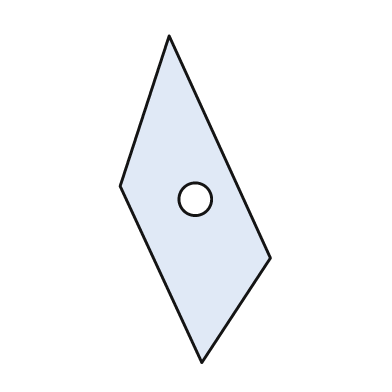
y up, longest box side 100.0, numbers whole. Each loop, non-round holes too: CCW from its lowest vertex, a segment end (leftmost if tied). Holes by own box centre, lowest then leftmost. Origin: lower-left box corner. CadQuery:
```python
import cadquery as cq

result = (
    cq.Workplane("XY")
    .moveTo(25.0, 0.0)
    .lineTo(46.0, 32.0)
    .lineTo(15.0, 100.0)
    .lineTo(0.0, 54.0)
    .close()
    .moveTo(23.0, 50.0)
    .circle(5.0)
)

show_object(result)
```